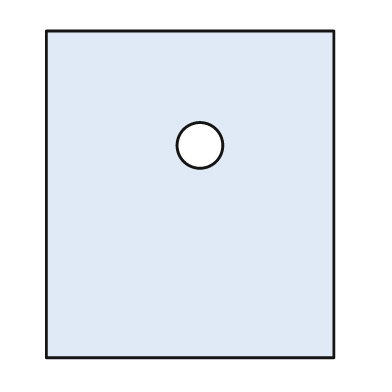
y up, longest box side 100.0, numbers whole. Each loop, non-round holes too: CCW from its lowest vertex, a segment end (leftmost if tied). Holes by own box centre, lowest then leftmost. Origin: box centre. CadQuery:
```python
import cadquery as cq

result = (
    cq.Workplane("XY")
    .moveTo(-44.0, -50.0)
    .lineTo(44.0, -50.0)
    .lineTo(44.0, 50.0)
    .lineTo(-44.0, 50.0)
    .close()
    .moveTo(3.0, 15.0)
    .circle(7.0)
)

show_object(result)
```